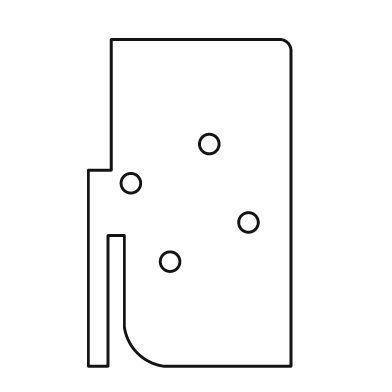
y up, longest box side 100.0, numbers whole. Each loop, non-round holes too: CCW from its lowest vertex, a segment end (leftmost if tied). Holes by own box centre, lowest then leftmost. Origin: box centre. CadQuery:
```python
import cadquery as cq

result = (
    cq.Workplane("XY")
    .moveTo(-31.0, -50.0)
    .lineTo(-25.0, -50.0)
    .lineTo(-25.0, -10.0)
    .lineTo(-20.0, -10.0)
    .lineTo(-20.0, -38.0)
    .threePointArc((-16.0, -46.0), (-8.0, -50.0))
    .lineTo(31.0, -50.0)
    .lineTo(31.0, 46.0)
    .threePointArc((30.0, 49.0), (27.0, 50.0))
    .lineTo(-24.0, 50.0)
    .lineTo(-24.0, 10.0)
    .lineTo(-31.0, 10.0)
    .close()
    .moveTo(-6.0, -18.0)
    .circle(3.0)
    .moveTo(18.0, -6.0)
    .circle(3.0)
    .moveTo(-18.0, 6.0)
    .circle(3.0)
    .moveTo(6.0, 18.0)
    .circle(3.0)
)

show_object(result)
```